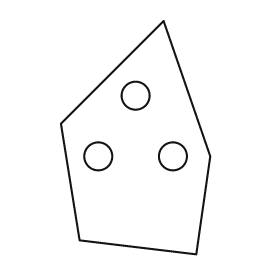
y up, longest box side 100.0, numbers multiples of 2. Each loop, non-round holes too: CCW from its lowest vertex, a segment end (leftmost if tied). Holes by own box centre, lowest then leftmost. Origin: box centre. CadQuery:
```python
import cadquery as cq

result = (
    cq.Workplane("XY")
    .moveTo(26.0, -50.0)
    .lineTo(32.0, -8.0)
    .lineTo(12.0, 50.0)
    .lineTo(-32.0, 6.0)
    .lineTo(-24.0, -44.0)
    .close()
    .moveTo(-16.0, -8.0)
    .circle(6.0)
    .moveTo(16.0, -8.0)
    .circle(6.0)
    .moveTo(0.0, 18.0)
    .circle(6.0)
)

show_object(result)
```